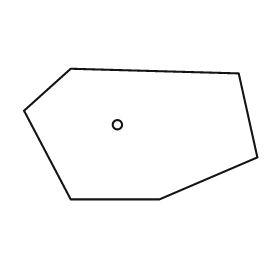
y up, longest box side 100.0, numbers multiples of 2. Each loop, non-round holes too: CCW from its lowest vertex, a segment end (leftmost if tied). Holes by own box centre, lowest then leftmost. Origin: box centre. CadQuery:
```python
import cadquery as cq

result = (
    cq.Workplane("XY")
    .moveTo(-30.0, -28.0)
    .lineTo(8.0, -28.0)
    .lineTo(50.0, -10.0)
    .lineTo(42.0, 26.0)
    .lineTo(-30.0, 28.0)
    .lineTo(-50.0, 10.0)
    .close()
    .moveTo(-10.0, 4.0)
    .circle(2.0)
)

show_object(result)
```